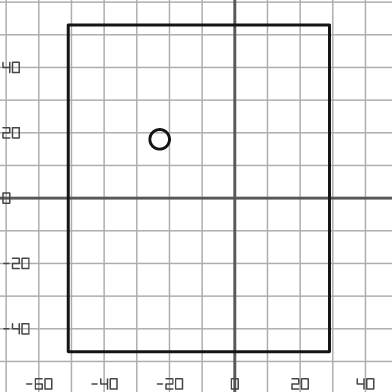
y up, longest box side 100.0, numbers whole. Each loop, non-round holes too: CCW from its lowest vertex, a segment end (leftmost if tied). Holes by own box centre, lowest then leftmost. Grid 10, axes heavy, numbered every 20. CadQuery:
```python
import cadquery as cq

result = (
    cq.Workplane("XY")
    .moveTo(-51.0, -47.0)
    .lineTo(29.0, -47.0)
    .lineTo(29.0, 53.0)
    .lineTo(-51.0, 53.0)
    .close()
    .moveTo(-23.0, 18.0)
    .circle(3.0)
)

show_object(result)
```